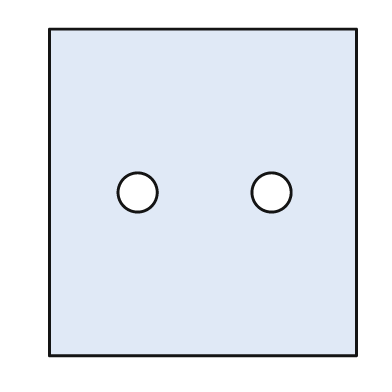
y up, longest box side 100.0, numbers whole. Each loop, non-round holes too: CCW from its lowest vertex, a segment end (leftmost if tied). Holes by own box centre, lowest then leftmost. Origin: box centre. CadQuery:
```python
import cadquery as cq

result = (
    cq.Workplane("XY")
    .moveTo(-47.0, -50.0)
    .lineTo(47.0, -50.0)
    .lineTo(47.0, 50.0)
    .lineTo(-47.0, 50.0)
    .close()
    .moveTo(-20.0, 0.0)
    .circle(6.0)
    .moveTo(21.0, 0.0)
    .circle(6.0)
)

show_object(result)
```